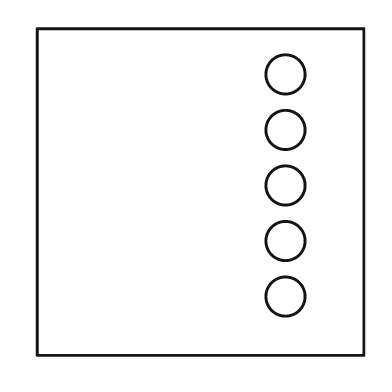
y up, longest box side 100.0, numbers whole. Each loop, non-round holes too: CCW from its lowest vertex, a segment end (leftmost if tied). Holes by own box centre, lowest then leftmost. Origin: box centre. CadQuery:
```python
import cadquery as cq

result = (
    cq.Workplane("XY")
    .moveTo(-50.0, -50.0)
    .lineTo(50.0, -50.0)
    .lineTo(50.0, 50.0)
    .lineTo(-50.0, 50.0)
    .close()
    .moveTo(26.0, -32.0)
    .circle(6.0)
    .moveTo(26.0, -15.0)
    .circle(6.0)
    .moveTo(26.0, 2.0)
    .circle(6.0)
    .moveTo(26.0, 19.0)
    .circle(6.0)
    .moveTo(26.0, 36.0)
    .circle(6.0)
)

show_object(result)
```